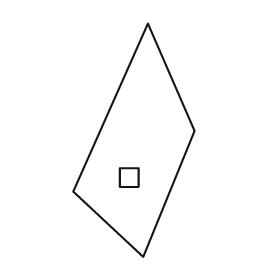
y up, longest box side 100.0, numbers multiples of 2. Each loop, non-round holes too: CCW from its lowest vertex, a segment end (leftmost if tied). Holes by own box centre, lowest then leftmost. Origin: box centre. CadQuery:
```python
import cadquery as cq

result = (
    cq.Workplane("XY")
    .moveTo(4.0, -50.0)
    .lineTo(26.0, 4.0)
    .lineTo(6.0, 50.0)
    .lineTo(-26.0, -22.0)
    .close()
    .moveTo(-6.0, -20.0)
    .lineTo(2.0, -20.0)
    .lineTo(2.0, -12.0)
    .lineTo(-6.0, -12.0)
    .close()
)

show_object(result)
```